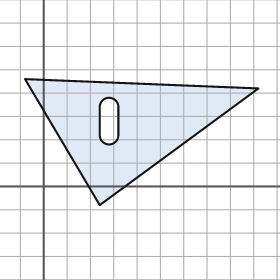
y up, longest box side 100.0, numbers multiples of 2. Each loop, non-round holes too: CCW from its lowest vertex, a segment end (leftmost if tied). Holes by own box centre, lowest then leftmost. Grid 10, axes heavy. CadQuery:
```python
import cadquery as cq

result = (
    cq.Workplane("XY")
    .moveTo(24.0, -8.0)
    .lineTo(92.0, 42.0)
    .lineTo(-8.0, 46.0)
    .close()
    .moveTo(24.0, 22.0)
    .threePointArc((28.0, 18.0), (32.0, 22.0))
    .lineTo(32.0, 34.0)
    .threePointArc((28.0, 38.0), (24.0, 34.0))
    .close()
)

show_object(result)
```